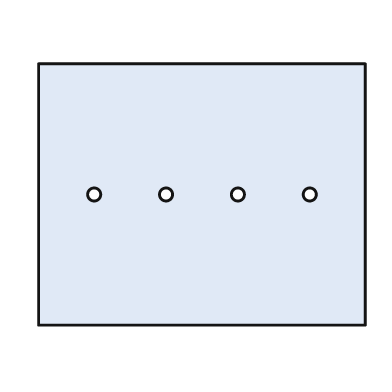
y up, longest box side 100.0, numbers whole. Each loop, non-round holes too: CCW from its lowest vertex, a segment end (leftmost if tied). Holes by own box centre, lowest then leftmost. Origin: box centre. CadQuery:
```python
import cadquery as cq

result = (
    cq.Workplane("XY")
    .moveTo(-50.0, -40.0)
    .lineTo(50.0, -40.0)
    .lineTo(50.0, 40.0)
    .lineTo(-50.0, 40.0)
    .close()
    .moveTo(-33.0, 0.0)
    .circle(2.0)
    .moveTo(-11.0, 0.0)
    .circle(2.0)
    .moveTo(11.0, 0.0)
    .circle(2.0)
    .moveTo(33.0, 0.0)
    .circle(2.0)
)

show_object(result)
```